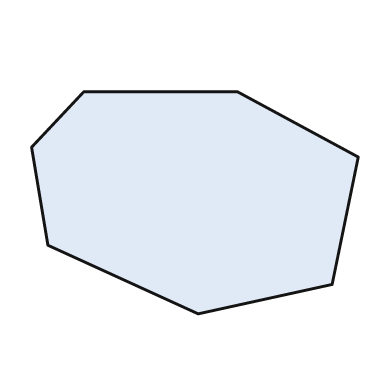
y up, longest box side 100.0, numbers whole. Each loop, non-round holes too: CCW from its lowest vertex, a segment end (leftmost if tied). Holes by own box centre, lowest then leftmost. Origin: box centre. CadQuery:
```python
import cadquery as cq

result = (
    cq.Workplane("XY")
    .moveTo(1.0, -34.0)
    .lineTo(42.0, -25.0)
    .lineTo(50.0, 14.0)
    .lineTo(13.0, 34.0)
    .lineTo(-34.0, 34.0)
    .lineTo(-50.0, 17.0)
    .lineTo(-45.0, -13.0)
    .close()
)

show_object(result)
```